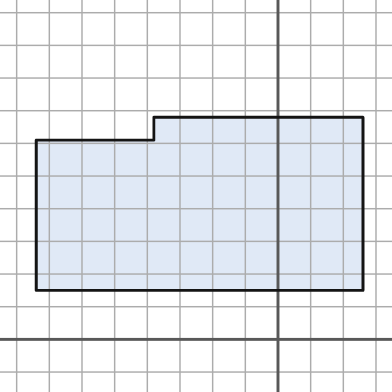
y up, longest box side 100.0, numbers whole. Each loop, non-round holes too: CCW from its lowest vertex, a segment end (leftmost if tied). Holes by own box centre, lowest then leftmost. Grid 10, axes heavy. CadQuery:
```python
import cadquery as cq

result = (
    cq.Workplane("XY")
    .moveTo(-74.0, 15.0)
    .lineTo(26.0, 15.0)
    .lineTo(26.0, 68.0)
    .lineTo(-38.0, 68.0)
    .lineTo(-38.0, 61.0)
    .lineTo(-74.0, 61.0)
    .close()
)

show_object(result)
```